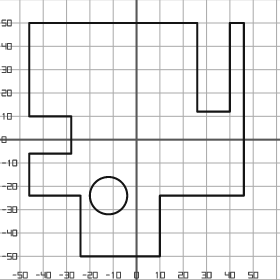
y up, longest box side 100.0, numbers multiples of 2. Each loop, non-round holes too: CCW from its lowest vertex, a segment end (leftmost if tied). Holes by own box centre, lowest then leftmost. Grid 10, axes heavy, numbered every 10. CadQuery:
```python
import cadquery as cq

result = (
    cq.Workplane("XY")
    .moveTo(-24.0, -50.0)
    .lineTo(10.0, -50.0)
    .lineTo(10.0, -24.0)
    .lineTo(46.0, -24.0)
    .lineTo(46.0, 50.0)
    .lineTo(40.0, 50.0)
    .lineTo(40.0, 12.0)
    .lineTo(26.0, 12.0)
    .lineTo(26.0, 50.0)
    .lineTo(-46.0, 50.0)
    .lineTo(-46.0, 10.0)
    .lineTo(-28.0, 10.0)
    .lineTo(-28.0, -6.0)
    .lineTo(-46.0, -6.0)
    .lineTo(-46.0, -24.0)
    .lineTo(-24.0, -24.0)
    .close()
    .moveTo(-12.0, -24.0)
    .circle(8.0)
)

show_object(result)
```